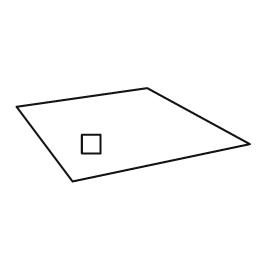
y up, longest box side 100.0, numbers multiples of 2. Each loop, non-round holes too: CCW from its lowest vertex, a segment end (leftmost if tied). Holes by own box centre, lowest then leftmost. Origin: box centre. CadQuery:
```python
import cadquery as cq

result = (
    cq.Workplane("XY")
    .moveTo(-26.0, -20.0)
    .lineTo(50.0, -4.0)
    .lineTo(6.0, 20.0)
    .lineTo(-50.0, 12.0)
    .close()
    .moveTo(-22.0, -8.0)
    .lineTo(-14.0, -8.0)
    .lineTo(-14.0, 0.0)
    .lineTo(-22.0, 0.0)
    .close()
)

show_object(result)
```